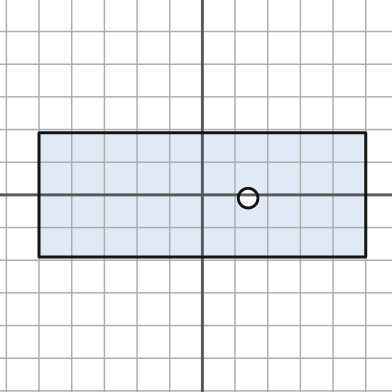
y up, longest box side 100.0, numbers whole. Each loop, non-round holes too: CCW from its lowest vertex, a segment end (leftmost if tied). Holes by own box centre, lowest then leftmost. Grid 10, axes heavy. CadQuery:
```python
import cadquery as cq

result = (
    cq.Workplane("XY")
    .moveTo(-50.0, -19.0)
    .lineTo(50.0, -19.0)
    .lineTo(50.0, 19.0)
    .lineTo(-50.0, 19.0)
    .close()
    .moveTo(14.0, -1.0)
    .circle(3.0)
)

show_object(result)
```